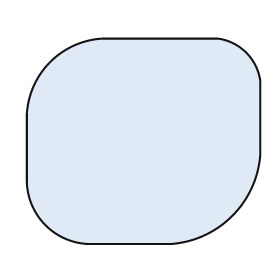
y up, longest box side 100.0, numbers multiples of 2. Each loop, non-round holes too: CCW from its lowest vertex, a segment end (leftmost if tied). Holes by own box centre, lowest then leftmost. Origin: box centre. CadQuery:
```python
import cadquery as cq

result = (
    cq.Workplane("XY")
    .moveTo(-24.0, -44.0)
    .lineTo(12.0, -44.0)
    .threePointArc((38.0, -32.0), (50.0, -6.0))
    .lineTo(50.0, 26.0)
    .threePointArc((44.0, 38.0), (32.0, 44.0))
    .lineTo(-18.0, 44.0)
    .threePointArc((-40.0, 34.0), (-50.0, 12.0))
    .lineTo(-50.0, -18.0)
    .threePointArc((-42.0, -36.0), (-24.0, -44.0))
    .close()
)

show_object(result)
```